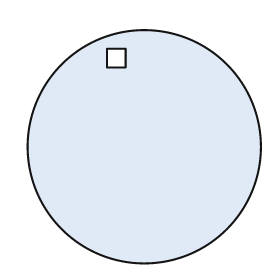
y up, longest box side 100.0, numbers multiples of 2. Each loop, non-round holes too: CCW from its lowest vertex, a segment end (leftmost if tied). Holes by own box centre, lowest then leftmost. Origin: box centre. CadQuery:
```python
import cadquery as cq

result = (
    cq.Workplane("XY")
    .moveTo(0.0, 0.0)
    .circle(50.0)
    .moveTo(-16.0, 34.0)
    .lineTo(-8.0, 34.0)
    .lineTo(-8.0, 42.0)
    .lineTo(-16.0, 42.0)
    .close()
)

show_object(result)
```